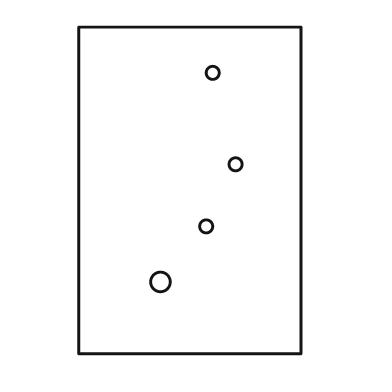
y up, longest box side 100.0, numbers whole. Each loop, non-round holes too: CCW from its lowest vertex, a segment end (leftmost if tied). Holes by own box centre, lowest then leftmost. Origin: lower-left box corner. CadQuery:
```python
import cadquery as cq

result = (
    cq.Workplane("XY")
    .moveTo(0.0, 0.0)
    .lineTo(68.0, 0.0)
    .lineTo(68.0, 100.0)
    .lineTo(0.0, 100.0)
    .close()
    .moveTo(25.0, 22.0)
    .circle(3.0)
    .moveTo(39.0, 39.0)
    .circle(2.0)
    .moveTo(48.0, 58.0)
    .circle(2.0)
    .moveTo(41.0, 86.0)
    .circle(2.0)
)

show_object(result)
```